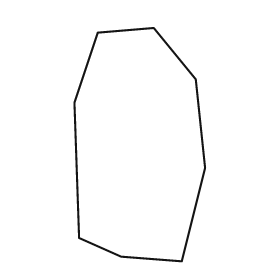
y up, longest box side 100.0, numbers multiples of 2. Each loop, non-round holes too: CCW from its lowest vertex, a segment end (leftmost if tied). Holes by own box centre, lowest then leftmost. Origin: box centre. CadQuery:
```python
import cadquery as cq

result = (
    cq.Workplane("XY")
    .moveTo(18.0, -50.0)
    .lineTo(28.0, -10.0)
    .lineTo(24.0, 28.0)
    .lineTo(6.0, 50.0)
    .lineTo(-18.0, 48.0)
    .lineTo(-28.0, 18.0)
    .lineTo(-26.0, -40.0)
    .lineTo(-8.0, -48.0)
    .close()
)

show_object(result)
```